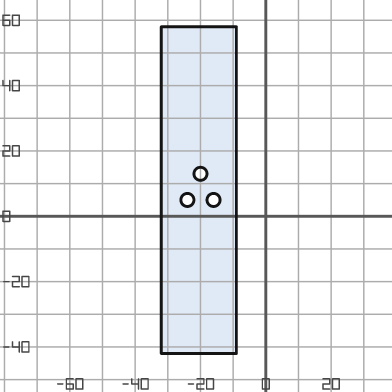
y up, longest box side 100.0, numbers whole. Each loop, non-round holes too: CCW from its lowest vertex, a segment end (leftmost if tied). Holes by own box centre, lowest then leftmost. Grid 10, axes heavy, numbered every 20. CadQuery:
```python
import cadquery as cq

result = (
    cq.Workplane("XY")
    .moveTo(-32.0, -42.0)
    .lineTo(-9.0, -42.0)
    .lineTo(-9.0, 58.0)
    .lineTo(-32.0, 58.0)
    .close()
    .moveTo(-24.0, 5.0)
    .circle(2.0)
    .moveTo(-16.0, 5.0)
    .circle(2.0)
    .moveTo(-20.0, 13.0)
    .circle(2.0)
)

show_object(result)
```